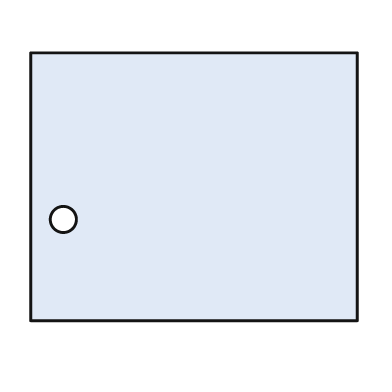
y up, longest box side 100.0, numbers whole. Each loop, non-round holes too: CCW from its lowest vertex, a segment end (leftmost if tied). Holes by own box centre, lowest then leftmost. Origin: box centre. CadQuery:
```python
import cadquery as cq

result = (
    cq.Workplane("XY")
    .moveTo(-50.0, -41.0)
    .lineTo(50.0, -41.0)
    .lineTo(50.0, 41.0)
    .lineTo(-50.0, 41.0)
    .close()
    .moveTo(-40.0, -10.0)
    .circle(4.0)
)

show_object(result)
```